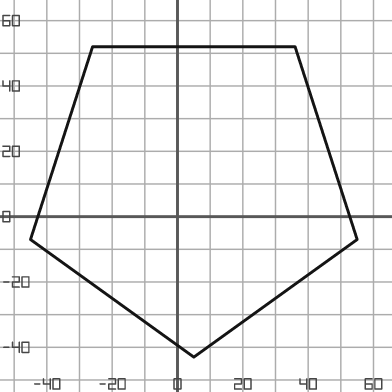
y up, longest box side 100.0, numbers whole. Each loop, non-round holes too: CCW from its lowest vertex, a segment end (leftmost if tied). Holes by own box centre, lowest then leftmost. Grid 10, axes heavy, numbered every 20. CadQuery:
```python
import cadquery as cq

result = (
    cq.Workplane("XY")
    .moveTo(5.0, -43.0)
    .lineTo(55.0, -7.0)
    .lineTo(36.0, 52.0)
    .lineTo(-26.0, 52.0)
    .lineTo(-45.0, -7.0)
    .close()
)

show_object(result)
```